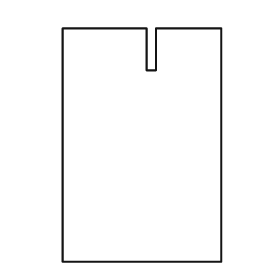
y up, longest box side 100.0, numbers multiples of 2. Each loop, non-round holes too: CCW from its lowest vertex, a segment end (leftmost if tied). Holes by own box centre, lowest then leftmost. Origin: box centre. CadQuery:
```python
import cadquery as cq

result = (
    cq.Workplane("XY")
    .moveTo(-34.0, -50.0)
    .lineTo(34.0, -50.0)
    .lineTo(34.0, 50.0)
    .lineTo(6.0, 50.0)
    .lineTo(6.0, 32.0)
    .lineTo(2.0, 32.0)
    .lineTo(2.0, 50.0)
    .lineTo(-34.0, 50.0)
    .close()
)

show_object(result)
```